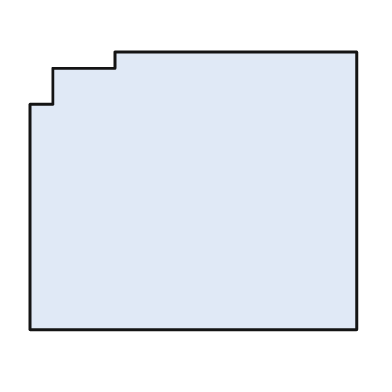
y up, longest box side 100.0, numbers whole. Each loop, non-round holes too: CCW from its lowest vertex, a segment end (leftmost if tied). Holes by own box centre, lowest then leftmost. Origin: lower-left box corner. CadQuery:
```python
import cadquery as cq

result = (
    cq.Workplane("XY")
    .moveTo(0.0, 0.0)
    .lineTo(100.0, 0.0)
    .lineTo(100.0, 85.0)
    .lineTo(26.0, 85.0)
    .lineTo(26.0, 80.0)
    .lineTo(7.0, 80.0)
    .lineTo(7.0, 69.0)
    .lineTo(0.0, 69.0)
    .close()
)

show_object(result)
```